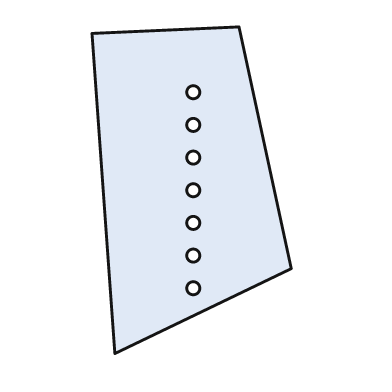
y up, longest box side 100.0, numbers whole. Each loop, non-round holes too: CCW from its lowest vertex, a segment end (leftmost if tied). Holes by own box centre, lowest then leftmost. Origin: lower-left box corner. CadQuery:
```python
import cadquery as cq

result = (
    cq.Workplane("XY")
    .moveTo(7.0, 0.0)
    .lineTo(61.0, 26.0)
    .lineTo(45.0, 100.0)
    .lineTo(0.0, 98.0)
    .close()
    .moveTo(31.0, 20.0)
    .circle(2.0)
    .moveTo(31.0, 30.0)
    .circle(2.0)
    .moveTo(31.0, 40.0)
    .circle(2.0)
    .moveTo(31.0, 50.0)
    .circle(2.0)
    .moveTo(31.0, 60.0)
    .circle(2.0)
    .moveTo(31.0, 70.0)
    .circle(2.0)
    .moveTo(31.0, 80.0)
    .circle(2.0)
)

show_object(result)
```